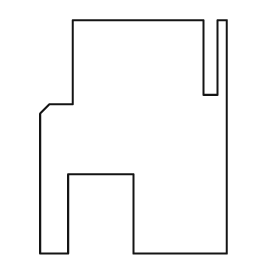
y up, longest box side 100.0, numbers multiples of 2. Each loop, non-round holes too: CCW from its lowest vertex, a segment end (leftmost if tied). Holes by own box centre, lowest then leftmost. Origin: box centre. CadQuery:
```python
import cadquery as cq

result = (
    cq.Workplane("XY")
    .moveTo(-40.0, -50.0)
    .lineTo(-28.0, -50.0)
    .lineTo(-28.0, -16.0)
    .lineTo(0.0, -16.0)
    .lineTo(0.0, -50.0)
    .lineTo(40.0, -50.0)
    .lineTo(40.0, 50.0)
    .lineTo(36.0, 50.0)
    .lineTo(36.0, 18.0)
    .lineTo(30.0, 18.0)
    .lineTo(30.0, 50.0)
    .lineTo(-26.0, 50.0)
    .lineTo(-26.0, 14.0)
    .lineTo(-36.0, 14.0)
    .lineTo(-40.0, 10.0)
    .close()
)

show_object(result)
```